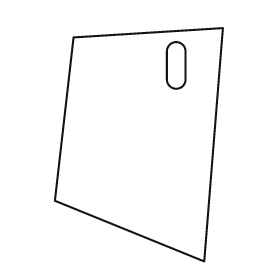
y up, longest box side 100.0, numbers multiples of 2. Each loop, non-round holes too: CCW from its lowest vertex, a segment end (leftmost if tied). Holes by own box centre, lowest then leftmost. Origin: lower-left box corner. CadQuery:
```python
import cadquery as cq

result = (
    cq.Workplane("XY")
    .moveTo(64.0, 0.0)
    .lineTo(72.0, 100.0)
    .lineTo(8.0, 96.0)
    .lineTo(0.0, 26.0)
    .close()
    .moveTo(48.0, 78.0)
    .threePointArc((52.0, 74.0), (56.0, 78.0))
    .lineTo(56.0, 90.0)
    .threePointArc((52.0, 94.0), (48.0, 90.0))
    .close()
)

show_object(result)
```